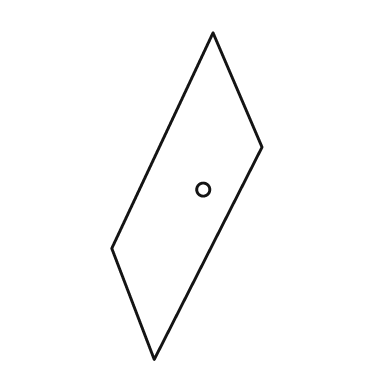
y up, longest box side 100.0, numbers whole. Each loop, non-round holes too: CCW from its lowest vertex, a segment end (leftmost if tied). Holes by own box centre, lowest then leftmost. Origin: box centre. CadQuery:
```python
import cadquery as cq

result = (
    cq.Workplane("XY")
    .moveTo(-10.0, -50.0)
    .lineTo(23.0, 15.0)
    .lineTo(8.0, 50.0)
    .lineTo(-23.0, -16.0)
    .close()
    .moveTo(5.0, 2.0)
    .circle(2.0)
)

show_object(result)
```